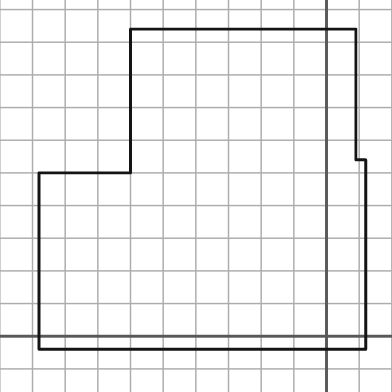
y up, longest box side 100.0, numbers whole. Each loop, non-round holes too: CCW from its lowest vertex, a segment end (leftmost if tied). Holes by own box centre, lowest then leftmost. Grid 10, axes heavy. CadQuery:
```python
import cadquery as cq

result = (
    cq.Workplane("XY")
    .moveTo(-88.0, -4.0)
    .lineTo(12.0, -4.0)
    .lineTo(12.0, 54.0)
    .lineTo(9.0, 54.0)
    .lineTo(9.0, 94.0)
    .lineTo(-60.0, 94.0)
    .lineTo(-60.0, 50.0)
    .lineTo(-88.0, 50.0)
    .close()
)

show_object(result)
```